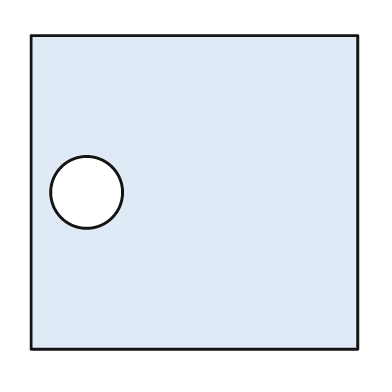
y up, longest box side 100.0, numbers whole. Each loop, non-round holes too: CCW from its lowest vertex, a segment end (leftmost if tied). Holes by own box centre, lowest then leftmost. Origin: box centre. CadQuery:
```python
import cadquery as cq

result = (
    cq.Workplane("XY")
    .moveTo(-50.0, -48.0)
    .lineTo(50.0, -48.0)
    .lineTo(50.0, 48.0)
    .lineTo(-50.0, 48.0)
    .close()
    .moveTo(-33.0, 0.0)
    .circle(11.0)
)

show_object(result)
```